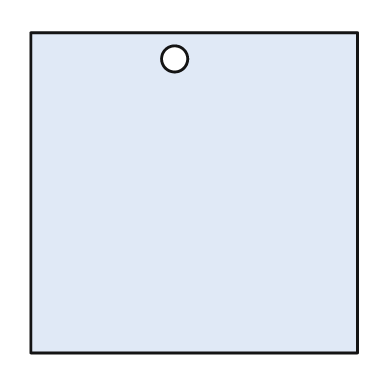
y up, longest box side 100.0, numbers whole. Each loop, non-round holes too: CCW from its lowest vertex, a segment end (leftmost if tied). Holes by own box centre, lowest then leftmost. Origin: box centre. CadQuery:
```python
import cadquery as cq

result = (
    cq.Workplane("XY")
    .moveTo(-50.0, -49.0)
    .lineTo(50.0, -49.0)
    .lineTo(50.0, 49.0)
    .lineTo(-50.0, 49.0)
    .close()
    .moveTo(-6.0, 41.0)
    .circle(4.0)
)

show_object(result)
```